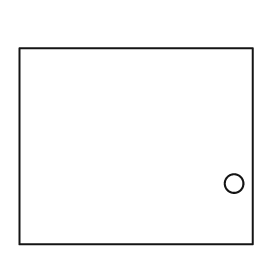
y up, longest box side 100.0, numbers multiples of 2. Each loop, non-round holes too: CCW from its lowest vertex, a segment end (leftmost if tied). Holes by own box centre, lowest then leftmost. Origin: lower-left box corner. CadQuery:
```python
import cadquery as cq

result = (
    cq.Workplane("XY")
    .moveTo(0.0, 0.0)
    .lineTo(100.0, 0.0)
    .lineTo(100.0, 84.0)
    .lineTo(0.0, 84.0)
    .close()
    .moveTo(92.0, 26.0)
    .circle(4.0)
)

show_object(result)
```